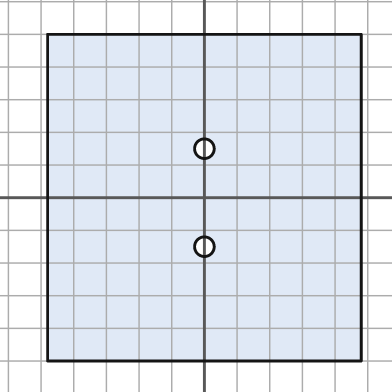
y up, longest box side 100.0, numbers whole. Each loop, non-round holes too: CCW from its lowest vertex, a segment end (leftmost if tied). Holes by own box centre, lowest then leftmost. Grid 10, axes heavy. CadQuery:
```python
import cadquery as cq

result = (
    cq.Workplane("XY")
    .moveTo(-48.0, -50.0)
    .lineTo(48.0, -50.0)
    .lineTo(48.0, 50.0)
    .lineTo(-48.0, 50.0)
    .close()
    .moveTo(0.0, -15.0)
    .circle(3.0)
    .moveTo(0.0, 15.0)
    .circle(3.0)
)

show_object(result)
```